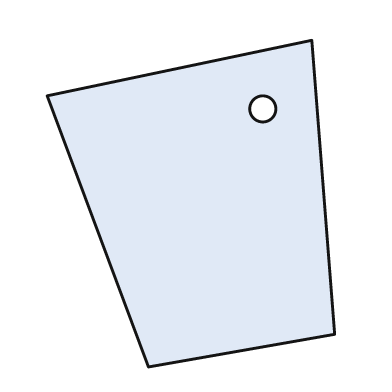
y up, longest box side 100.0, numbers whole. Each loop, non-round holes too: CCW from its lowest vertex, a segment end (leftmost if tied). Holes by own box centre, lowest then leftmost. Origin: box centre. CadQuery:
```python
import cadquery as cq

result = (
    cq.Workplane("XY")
    .moveTo(-13.0, -50.0)
    .lineTo(44.0, -40.0)
    .lineTo(37.0, 50.0)
    .lineTo(-44.0, 33.0)
    .close()
    .moveTo(22.0, 29.0)
    .circle(4.0)
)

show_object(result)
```